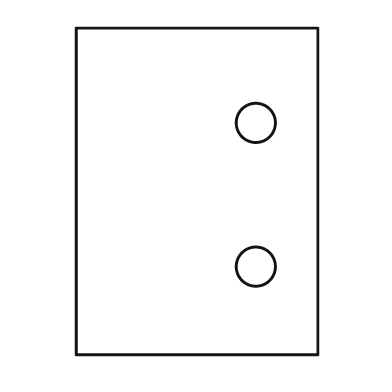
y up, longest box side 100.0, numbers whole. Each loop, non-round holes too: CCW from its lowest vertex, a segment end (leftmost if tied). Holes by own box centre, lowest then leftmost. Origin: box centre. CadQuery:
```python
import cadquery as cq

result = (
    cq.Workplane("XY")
    .moveTo(-37.0, -50.0)
    .lineTo(37.0, -50.0)
    .lineTo(37.0, 50.0)
    .lineTo(-37.0, 50.0)
    .close()
    .moveTo(18.0, -23.0)
    .circle(6.0)
    .moveTo(18.0, 21.0)
    .circle(6.0)
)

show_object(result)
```